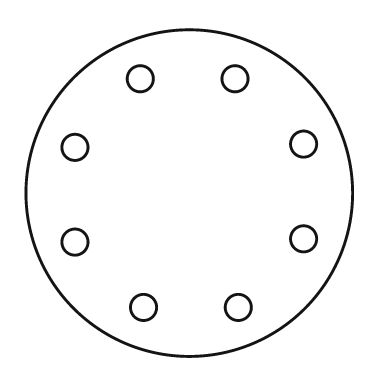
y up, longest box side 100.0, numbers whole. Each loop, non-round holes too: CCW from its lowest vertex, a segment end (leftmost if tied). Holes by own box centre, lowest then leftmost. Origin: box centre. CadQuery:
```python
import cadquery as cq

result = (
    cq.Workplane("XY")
    .moveTo(0.0, 0.0)
    .circle(50.0)
    .moveTo(-14.0, -35.0)
    .circle(4.0)
    .moveTo(15.0, -35.0)
    .circle(4.0)
    .moveTo(-35.0, -15.0)
    .circle(4.0)
    .moveTo(35.0, -14.0)
    .circle(4.0)
    .moveTo(-35.0, 14.0)
    .circle(4.0)
    .moveTo(35.0, 15.0)
    .circle(4.0)
    .moveTo(-15.0, 35.0)
    .circle(4.0)
    .moveTo(14.0, 35.0)
    .circle(4.0)
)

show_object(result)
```